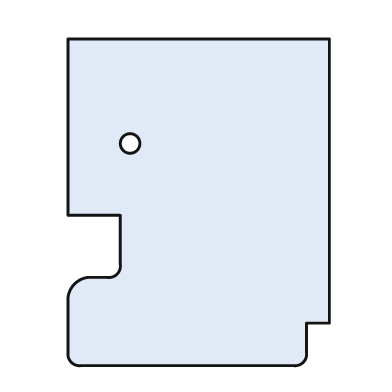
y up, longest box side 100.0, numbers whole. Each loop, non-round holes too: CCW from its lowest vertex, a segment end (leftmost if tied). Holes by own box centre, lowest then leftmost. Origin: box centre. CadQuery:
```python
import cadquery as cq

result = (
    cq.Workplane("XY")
    .moveTo(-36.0, -50.0)
    .lineTo(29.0, -50.0)
    .threePointArc((32.0, -49.0), (33.0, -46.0))
    .lineTo(33.0, -37.0)
    .lineTo(40.0, -37.0)
    .lineTo(40.0, 50.0)
    .lineTo(-40.0, 50.0)
    .lineTo(-40.0, -4.0)
    .lineTo(-24.0, -4.0)
    .lineTo(-24.0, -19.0)
    .threePointArc((-25.0, -22.0), (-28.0, -23.0))
    .lineTo(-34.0, -23.0)
    .threePointArc((-38.0, -25.0), (-40.0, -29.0))
    .lineTo(-40.0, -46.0)
    .threePointArc((-39.0, -49.0), (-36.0, -50.0))
    .close()
    .moveTo(-21.0, 18.0)
    .circle(3.0)
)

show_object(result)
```